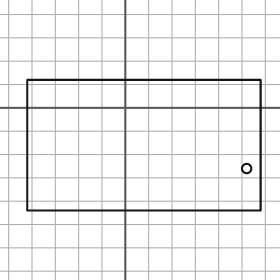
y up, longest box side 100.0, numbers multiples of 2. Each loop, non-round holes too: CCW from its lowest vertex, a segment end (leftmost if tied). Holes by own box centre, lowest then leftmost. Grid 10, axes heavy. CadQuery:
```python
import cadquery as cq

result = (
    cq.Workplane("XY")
    .moveTo(-42.0, -44.0)
    .lineTo(58.0, -44.0)
    .lineTo(58.0, 12.0)
    .lineTo(-42.0, 12.0)
    .close()
    .moveTo(52.0, -26.0)
    .circle(2.0)
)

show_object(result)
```